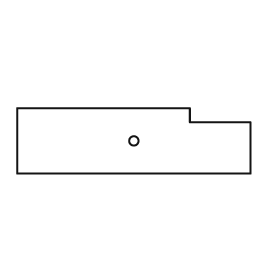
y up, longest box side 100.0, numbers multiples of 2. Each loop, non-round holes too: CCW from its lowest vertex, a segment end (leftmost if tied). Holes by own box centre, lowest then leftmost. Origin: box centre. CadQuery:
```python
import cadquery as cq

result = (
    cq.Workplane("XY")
    .moveTo(-50.0, -14.0)
    .lineTo(50.0, -14.0)
    .lineTo(50.0, 8.0)
    .lineTo(24.0, 8.0)
    .lineTo(24.0, 14.0)
    .lineTo(-50.0, 14.0)
    .close()
    .moveTo(0.0, 0.0)
    .circle(2.0)
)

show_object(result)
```